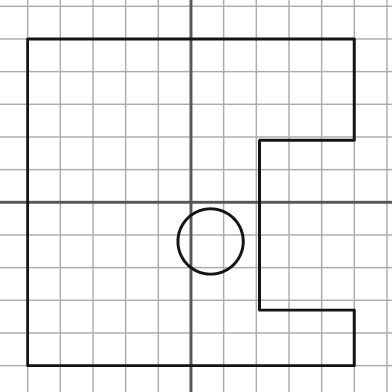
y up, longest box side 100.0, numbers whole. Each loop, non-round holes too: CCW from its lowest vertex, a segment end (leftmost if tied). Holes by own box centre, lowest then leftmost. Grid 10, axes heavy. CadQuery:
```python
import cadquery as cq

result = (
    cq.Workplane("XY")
    .moveTo(-50.0, -50.0)
    .lineTo(50.0, -50.0)
    .lineTo(50.0, -33.0)
    .lineTo(21.0, -33.0)
    .lineTo(21.0, 19.0)
    .lineTo(50.0, 19.0)
    .lineTo(50.0, 50.0)
    .lineTo(-50.0, 50.0)
    .close()
    .moveTo(6.0, -12.0)
    .circle(10.0)
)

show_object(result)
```